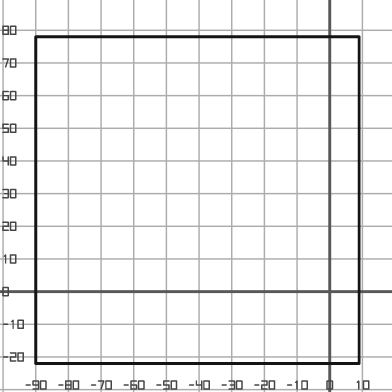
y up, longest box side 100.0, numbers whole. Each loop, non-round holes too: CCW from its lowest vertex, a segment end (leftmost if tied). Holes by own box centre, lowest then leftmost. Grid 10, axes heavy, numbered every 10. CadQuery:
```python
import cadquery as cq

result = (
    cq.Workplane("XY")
    .moveTo(-90.0, -22.0)
    .lineTo(9.0, -22.0)
    .lineTo(9.0, 78.0)
    .lineTo(-90.0, 78.0)
    .close()
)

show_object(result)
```